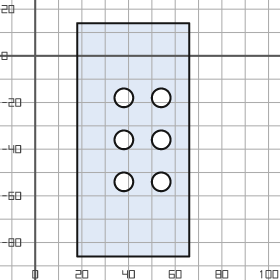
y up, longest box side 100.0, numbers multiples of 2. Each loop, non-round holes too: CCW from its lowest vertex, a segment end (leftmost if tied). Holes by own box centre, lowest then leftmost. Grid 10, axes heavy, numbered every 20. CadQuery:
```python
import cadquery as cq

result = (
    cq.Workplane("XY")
    .moveTo(18.0, -86.0)
    .lineTo(66.0, -86.0)
    .lineTo(66.0, 14.0)
    .lineTo(18.0, 14.0)
    .close()
    .moveTo(38.0, -54.0)
    .circle(4.0)
    .moveTo(54.0, -54.0)
    .circle(4.0)
    .moveTo(38.0, -36.0)
    .circle(4.0)
    .moveTo(54.0, -36.0)
    .circle(4.0)
    .moveTo(38.0, -18.0)
    .circle(4.0)
    .moveTo(54.0, -18.0)
    .circle(4.0)
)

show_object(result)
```